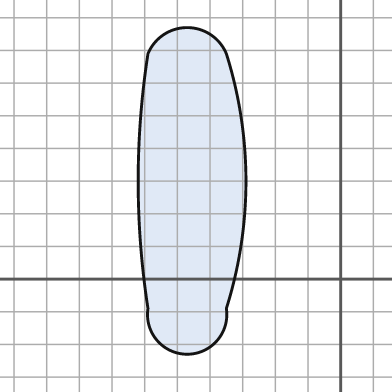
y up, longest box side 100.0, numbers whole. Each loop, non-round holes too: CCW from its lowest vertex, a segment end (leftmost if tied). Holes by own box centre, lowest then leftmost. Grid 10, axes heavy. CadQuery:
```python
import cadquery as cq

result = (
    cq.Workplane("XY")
    .moveTo(-59.0, -9.0)
    .threePointArc((-47.0, -23.0), (-35.0, -9.0))
    .threePointArc((-29.0, 30.0), (-35.0, 69.0))
    .threePointArc((-47.0, 77.0), (-59.0, 69.0))
    .threePointArc((-62.0, 30.0), (-59.0, -9.0))
    .close()
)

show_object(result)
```